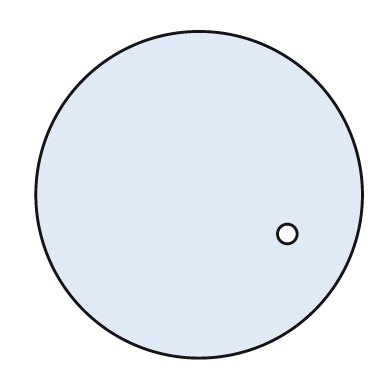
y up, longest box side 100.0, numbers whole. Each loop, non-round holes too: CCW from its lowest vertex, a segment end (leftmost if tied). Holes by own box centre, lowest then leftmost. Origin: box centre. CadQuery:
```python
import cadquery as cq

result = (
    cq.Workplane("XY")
    .moveTo(0.0, 0.0)
    .circle(50.0)
    .moveTo(27.0, -12.0)
    .circle(3.0)
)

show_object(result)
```